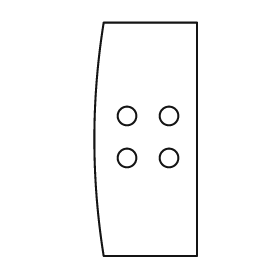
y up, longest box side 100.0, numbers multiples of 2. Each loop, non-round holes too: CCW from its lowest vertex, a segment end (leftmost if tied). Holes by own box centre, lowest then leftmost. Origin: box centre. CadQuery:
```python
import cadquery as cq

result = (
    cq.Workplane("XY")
    .moveTo(-18.0, -50.0)
    .lineTo(22.0, -50.0)
    .lineTo(22.0, 50.0)
    .lineTo(-18.0, 50.0)
    .threePointArc((-22.0, 0.0), (-18.0, -50.0))
    .close()
    .moveTo(-8.0, -8.0)
    .circle(4.0)
    .moveTo(10.0, -8.0)
    .circle(4.0)
    .moveTo(-8.0, 10.0)
    .circle(4.0)
    .moveTo(10.0, 10.0)
    .circle(4.0)
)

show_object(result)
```